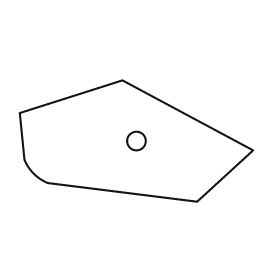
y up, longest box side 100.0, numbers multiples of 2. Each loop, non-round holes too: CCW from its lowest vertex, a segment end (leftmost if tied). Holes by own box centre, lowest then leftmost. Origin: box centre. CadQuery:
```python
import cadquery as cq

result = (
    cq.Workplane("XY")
    .moveTo(26.0, -26.0)
    .lineTo(50.0, -4.0)
    .lineTo(-6.0, 26.0)
    .lineTo(-50.0, 12.0)
    .lineTo(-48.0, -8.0)
    .threePointArc((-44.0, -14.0), (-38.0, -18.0))
    .close()
    .moveTo(0.0, 0.0)
    .circle(4.0)
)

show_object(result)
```